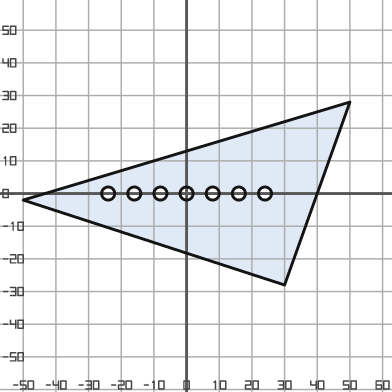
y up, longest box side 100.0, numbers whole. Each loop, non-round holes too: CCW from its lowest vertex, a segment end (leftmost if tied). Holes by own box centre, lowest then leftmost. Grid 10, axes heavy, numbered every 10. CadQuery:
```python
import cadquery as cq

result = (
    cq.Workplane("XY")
    .moveTo(30.0, -28.0)
    .lineTo(50.0, 28.0)
    .lineTo(-50.0, -2.0)
    .close()
    .moveTo(-24.0, 0.0)
    .circle(2.0)
    .moveTo(-16.0, 0.0)
    .circle(2.0)
    .moveTo(-8.0, 0.0)
    .circle(2.0)
    .moveTo(0.0, 0.0)
    .circle(2.0)
    .moveTo(8.0, 0.0)
    .circle(2.0)
    .moveTo(16.0, 0.0)
    .circle(2.0)
    .moveTo(24.0, 0.0)
    .circle(2.0)
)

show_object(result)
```